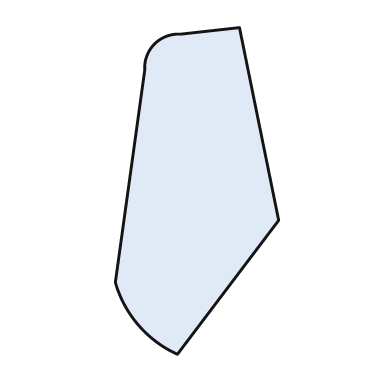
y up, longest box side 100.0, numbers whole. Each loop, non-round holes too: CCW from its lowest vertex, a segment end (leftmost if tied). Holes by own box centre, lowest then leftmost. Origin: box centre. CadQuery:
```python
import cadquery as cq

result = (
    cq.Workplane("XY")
    .moveTo(-6.0, -50.0)
    .lineTo(25.0, -9.0)
    .lineTo(13.0, 50.0)
    .lineTo(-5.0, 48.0)
    .threePointArc((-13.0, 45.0), (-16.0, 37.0))
    .lineTo(-25.0, -28.0)
    .threePointArc((-18.0, -41.0), (-6.0, -50.0))
    .close()
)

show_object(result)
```